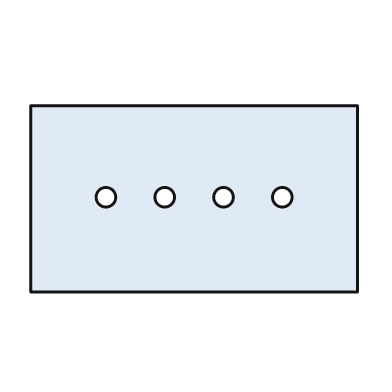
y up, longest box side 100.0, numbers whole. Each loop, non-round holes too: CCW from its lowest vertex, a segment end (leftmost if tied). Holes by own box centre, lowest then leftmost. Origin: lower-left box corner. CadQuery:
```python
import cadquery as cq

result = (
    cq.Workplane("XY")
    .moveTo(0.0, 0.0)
    .lineTo(100.0, 0.0)
    .lineTo(100.0, 57.0)
    .lineTo(0.0, 57.0)
    .close()
    .moveTo(23.0, 29.0)
    .circle(3.0)
    .moveTo(41.0, 29.0)
    .circle(3.0)
    .moveTo(59.0, 29.0)
    .circle(3.0)
    .moveTo(77.0, 29.0)
    .circle(3.0)
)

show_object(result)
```